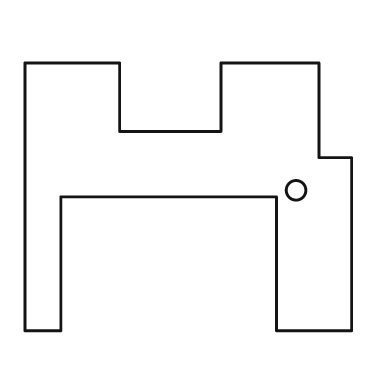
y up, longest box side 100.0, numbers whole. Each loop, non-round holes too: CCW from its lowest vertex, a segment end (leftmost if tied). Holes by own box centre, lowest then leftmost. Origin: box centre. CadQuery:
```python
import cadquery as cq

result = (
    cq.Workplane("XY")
    .moveTo(-50.0, -41.0)
    .lineTo(-39.0, -41.0)
    .lineTo(-39.0, 0.0)
    .lineTo(27.0, 0.0)
    .lineTo(27.0, -41.0)
    .lineTo(50.0, -41.0)
    .lineTo(50.0, 12.0)
    .lineTo(40.0, 12.0)
    .lineTo(40.0, 41.0)
    .lineTo(10.0, 41.0)
    .lineTo(10.0, 20.0)
    .lineTo(-21.0, 20.0)
    .lineTo(-21.0, 41.0)
    .lineTo(-50.0, 41.0)
    .close()
    .moveTo(33.0, 2.0)
    .circle(3.0)
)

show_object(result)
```